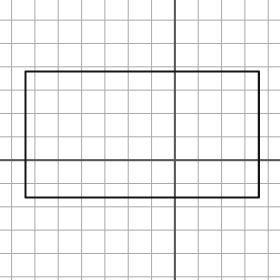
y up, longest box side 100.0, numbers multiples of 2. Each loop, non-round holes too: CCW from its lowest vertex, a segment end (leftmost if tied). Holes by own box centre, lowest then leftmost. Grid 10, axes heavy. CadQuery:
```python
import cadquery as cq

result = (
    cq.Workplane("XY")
    .moveTo(-64.0, -16.0)
    .lineTo(36.0, -16.0)
    .lineTo(36.0, 38.0)
    .lineTo(-64.0, 38.0)
    .close()
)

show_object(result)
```